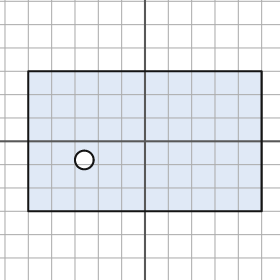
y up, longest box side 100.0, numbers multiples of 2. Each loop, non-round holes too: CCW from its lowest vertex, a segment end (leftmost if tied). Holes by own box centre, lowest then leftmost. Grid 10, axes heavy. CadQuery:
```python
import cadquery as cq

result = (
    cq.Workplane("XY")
    .moveTo(-50.0, -30.0)
    .lineTo(50.0, -30.0)
    .lineTo(50.0, 30.0)
    .lineTo(-50.0, 30.0)
    .close()
    .moveTo(-26.0, -8.0)
    .circle(4.0)
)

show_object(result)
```